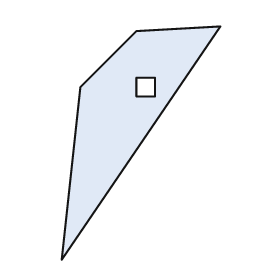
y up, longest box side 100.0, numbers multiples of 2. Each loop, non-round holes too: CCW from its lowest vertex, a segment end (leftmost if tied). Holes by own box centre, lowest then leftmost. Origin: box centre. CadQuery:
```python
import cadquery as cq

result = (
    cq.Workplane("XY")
    .moveTo(-34.0, -50.0)
    .lineTo(34.0, 50.0)
    .lineTo(-2.0, 48.0)
    .lineTo(-26.0, 24.0)
    .close()
    .moveTo(-2.0, 20.0)
    .lineTo(6.0, 20.0)
    .lineTo(6.0, 28.0)
    .lineTo(-2.0, 28.0)
    .close()
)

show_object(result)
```